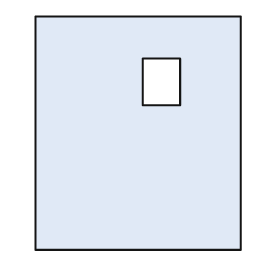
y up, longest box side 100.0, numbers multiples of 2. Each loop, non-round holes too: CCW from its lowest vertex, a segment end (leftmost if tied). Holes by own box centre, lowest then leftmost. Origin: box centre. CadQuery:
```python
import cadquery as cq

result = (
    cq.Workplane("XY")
    .moveTo(-44.0, -50.0)
    .lineTo(44.0, -50.0)
    .lineTo(44.0, 50.0)
    .lineTo(-44.0, 50.0)
    .close()
    .moveTo(2.0, 12.0)
    .lineTo(18.0, 12.0)
    .lineTo(18.0, 32.0)
    .lineTo(2.0, 32.0)
    .close()
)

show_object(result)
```